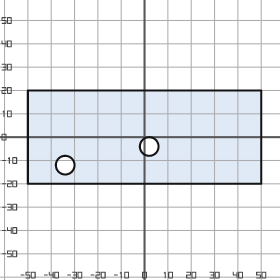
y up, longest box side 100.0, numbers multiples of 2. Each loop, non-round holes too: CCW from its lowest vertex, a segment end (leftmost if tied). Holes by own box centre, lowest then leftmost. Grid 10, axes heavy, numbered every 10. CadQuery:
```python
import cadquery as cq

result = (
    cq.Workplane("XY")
    .moveTo(-50.0, -20.0)
    .lineTo(50.0, -20.0)
    .lineTo(50.0, 20.0)
    .lineTo(-50.0, 20.0)
    .close()
    .moveTo(-34.0, -12.0)
    .circle(4.0)
    .moveTo(2.0, -4.0)
    .circle(4.0)
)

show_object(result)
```